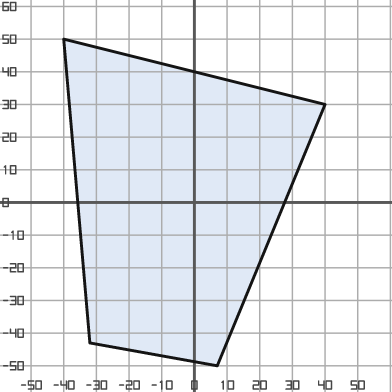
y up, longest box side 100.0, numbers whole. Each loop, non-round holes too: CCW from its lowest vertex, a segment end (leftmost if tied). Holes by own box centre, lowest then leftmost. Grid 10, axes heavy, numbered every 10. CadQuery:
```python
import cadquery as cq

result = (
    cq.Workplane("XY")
    .moveTo(7.0, -50.0)
    .lineTo(40.0, 30.0)
    .lineTo(-40.0, 50.0)
    .lineTo(-32.0, -43.0)
    .close()
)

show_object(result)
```